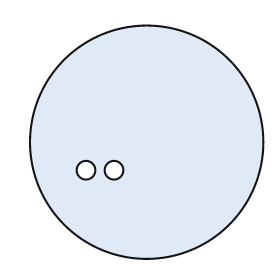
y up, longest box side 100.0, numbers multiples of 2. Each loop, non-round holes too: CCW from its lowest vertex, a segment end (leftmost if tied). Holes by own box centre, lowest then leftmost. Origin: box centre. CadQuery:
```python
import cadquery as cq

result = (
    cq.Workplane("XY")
    .moveTo(0.0, 0.0)
    .circle(50.0)
    .moveTo(-26.0, -12.0)
    .circle(4.0)
    .moveTo(-14.0, -12.0)
    .circle(4.0)
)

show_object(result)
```